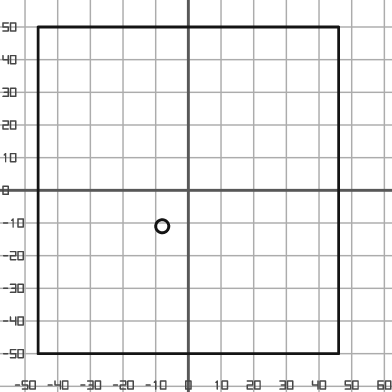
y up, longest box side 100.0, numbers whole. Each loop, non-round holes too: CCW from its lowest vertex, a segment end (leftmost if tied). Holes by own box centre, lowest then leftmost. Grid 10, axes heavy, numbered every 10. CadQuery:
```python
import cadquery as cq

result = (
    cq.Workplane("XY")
    .moveTo(-46.0, -50.0)
    .lineTo(46.0, -50.0)
    .lineTo(46.0, 50.0)
    .lineTo(-46.0, 50.0)
    .close()
    .moveTo(-8.0, -11.0)
    .circle(2.0)
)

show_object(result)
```